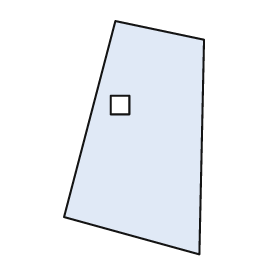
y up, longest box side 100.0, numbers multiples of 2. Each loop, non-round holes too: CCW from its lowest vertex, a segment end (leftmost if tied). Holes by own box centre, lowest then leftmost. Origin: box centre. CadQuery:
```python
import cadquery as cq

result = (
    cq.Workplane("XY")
    .moveTo(28.0, -50.0)
    .lineTo(30.0, 42.0)
    .lineTo(-8.0, 50.0)
    .lineTo(-30.0, -34.0)
    .close()
    .moveTo(-10.0, 10.0)
    .lineTo(-2.0, 10.0)
    .lineTo(-2.0, 18.0)
    .lineTo(-10.0, 18.0)
    .close()
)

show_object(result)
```